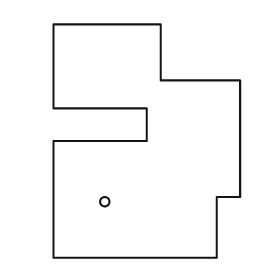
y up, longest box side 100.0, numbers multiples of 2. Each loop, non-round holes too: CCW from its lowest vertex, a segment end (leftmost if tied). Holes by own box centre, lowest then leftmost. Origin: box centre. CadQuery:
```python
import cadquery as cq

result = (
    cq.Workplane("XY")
    .moveTo(-40.0, -50.0)
    .lineTo(30.0, -50.0)
    .lineTo(30.0, -24.0)
    .lineTo(40.0, -24.0)
    .lineTo(40.0, 26.0)
    .lineTo(6.0, 26.0)
    .lineTo(6.0, 50.0)
    .lineTo(-40.0, 50.0)
    .lineTo(-40.0, 14.0)
    .lineTo(0.0, 14.0)
    .lineTo(0.0, 0.0)
    .lineTo(-40.0, 0.0)
    .close()
    .moveTo(-18.0, -26.0)
    .circle(2.0)
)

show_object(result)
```